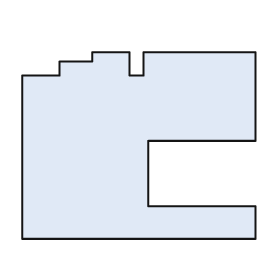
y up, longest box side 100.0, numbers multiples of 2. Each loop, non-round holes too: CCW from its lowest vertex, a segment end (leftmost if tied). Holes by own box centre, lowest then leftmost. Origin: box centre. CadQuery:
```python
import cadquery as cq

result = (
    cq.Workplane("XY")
    .moveTo(-50.0, -40.0)
    .lineTo(50.0, -40.0)
    .lineTo(50.0, -26.0)
    .lineTo(4.0, -26.0)
    .lineTo(4.0, 2.0)
    .lineTo(50.0, 2.0)
    .lineTo(50.0, 40.0)
    .lineTo(2.0, 40.0)
    .lineTo(2.0, 30.0)
    .lineTo(-4.0, 30.0)
    .lineTo(-4.0, 40.0)
    .lineTo(-20.0, 40.0)
    .lineTo(-20.0, 36.0)
    .lineTo(-34.0, 36.0)
    .lineTo(-34.0, 30.0)
    .lineTo(-50.0, 30.0)
    .close()
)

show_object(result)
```